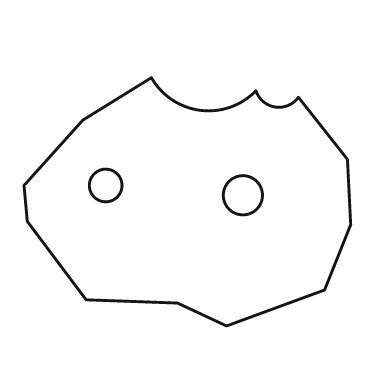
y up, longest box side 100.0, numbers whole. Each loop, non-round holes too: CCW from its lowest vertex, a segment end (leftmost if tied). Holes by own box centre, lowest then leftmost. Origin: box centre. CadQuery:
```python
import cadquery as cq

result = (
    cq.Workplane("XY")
    .moveTo(12.0, -38.0)
    .lineTo(42.0, -27.0)
    .lineTo(50.0, -7.0)
    .lineTo(49.0, 13.0)
    .lineTo(34.0, 32.0)
    .threePointArc((27.0, 29.0), (21.0, 34.0))
    .threePointArc((4.0, 28.0), (-11.0, 38.0))
    .lineTo(-32.0, 25.0)
    .lineTo(-50.0, 5.0)
    .lineTo(-49.0, -6.0)
    .lineTo(-31.0, -30.0)
    .lineTo(-3.0, -31.0)
    .close()
    .moveTo(17.0, 2.0)
    .circle(6.0)
    .moveTo(-25.0, 5.0)
    .circle(5.0)
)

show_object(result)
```